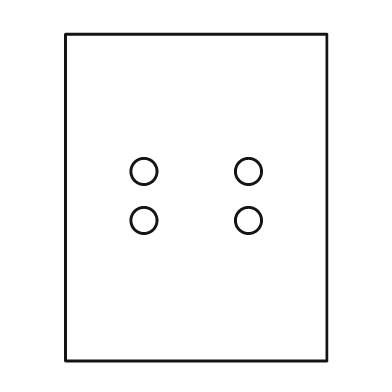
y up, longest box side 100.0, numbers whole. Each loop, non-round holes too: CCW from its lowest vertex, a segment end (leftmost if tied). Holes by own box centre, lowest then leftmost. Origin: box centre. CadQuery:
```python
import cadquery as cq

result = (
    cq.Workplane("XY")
    .moveTo(-40.0, -50.0)
    .lineTo(40.0, -50.0)
    .lineTo(40.0, 50.0)
    .lineTo(-40.0, 50.0)
    .close()
    .moveTo(-16.0, -7.0)
    .circle(4.0)
    .moveTo(16.0, -7.0)
    .circle(4.0)
    .moveTo(-16.0, 8.0)
    .circle(4.0)
    .moveTo(16.0, 8.0)
    .circle(4.0)
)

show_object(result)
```